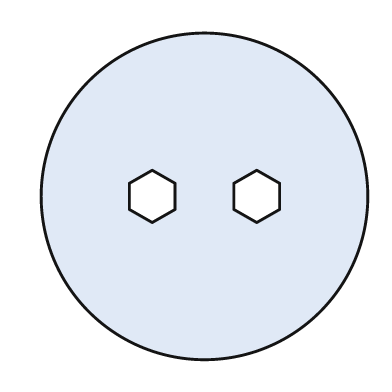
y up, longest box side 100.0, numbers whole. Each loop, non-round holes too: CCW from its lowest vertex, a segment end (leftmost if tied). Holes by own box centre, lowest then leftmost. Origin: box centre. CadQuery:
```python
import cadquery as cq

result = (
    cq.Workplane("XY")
    .moveTo(0.0, 0.0)
    .circle(50.0)
    .moveTo(-16.0, -8.0)
    .lineTo(-9.0, -4.0)
    .lineTo(-9.0, 4.0)
    .lineTo(-16.0, 8.0)
    .lineTo(-23.0, 4.0)
    .lineTo(-23.0, -4.0)
    .close()
    .moveTo(16.0, -8.0)
    .lineTo(23.0, -4.0)
    .lineTo(23.0, 4.0)
    .lineTo(16.0, 8.0)
    .lineTo(9.0, 4.0)
    .lineTo(9.0, -4.0)
    .close()
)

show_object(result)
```